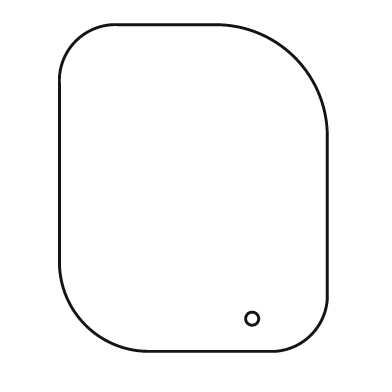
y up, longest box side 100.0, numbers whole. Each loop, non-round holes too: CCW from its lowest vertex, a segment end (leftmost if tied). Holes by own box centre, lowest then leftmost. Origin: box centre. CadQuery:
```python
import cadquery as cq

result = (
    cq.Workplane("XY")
    .moveTo(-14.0, -50.0)
    .lineTo(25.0, -50.0)
    .threePointArc((36.0, -45.0), (41.0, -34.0))
    .lineTo(41.0, 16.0)
    .threePointArc((31.0, 40.0), (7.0, 50.0))
    .lineTo(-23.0, 50.0)
    .threePointArc((-36.0, 45.0), (-41.0, 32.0))
    .lineTo(-41.0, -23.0)
    .threePointArc((-33.0, -42.0), (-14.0, -50.0))
    .close()
    .moveTo(18.0, -40.0)
    .circle(2.0)
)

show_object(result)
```